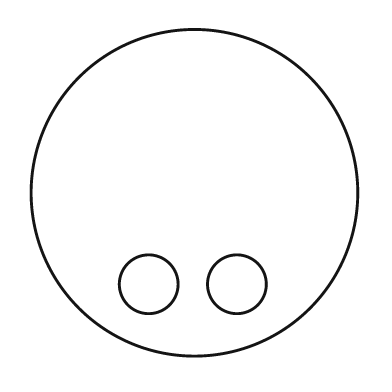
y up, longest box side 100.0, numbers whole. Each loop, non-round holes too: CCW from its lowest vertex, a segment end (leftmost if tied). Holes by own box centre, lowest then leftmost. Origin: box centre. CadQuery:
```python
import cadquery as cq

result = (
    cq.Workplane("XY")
    .moveTo(0.0, 0.0)
    .circle(50.0)
    .moveTo(-14.0, -28.0)
    .circle(9.0)
    .moveTo(13.0, -28.0)
    .circle(9.0)
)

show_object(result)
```